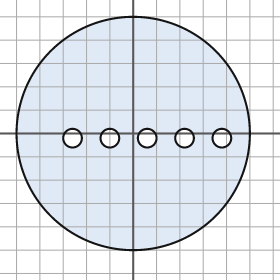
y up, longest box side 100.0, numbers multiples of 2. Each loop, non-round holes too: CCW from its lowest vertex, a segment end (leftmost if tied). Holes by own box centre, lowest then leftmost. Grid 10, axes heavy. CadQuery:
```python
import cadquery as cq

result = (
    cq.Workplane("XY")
    .moveTo(0.0, 0.0)
    .circle(50.0)
    .moveTo(-26.0, -2.0)
    .circle(4.0)
    .moveTo(-10.0, -2.0)
    .circle(4.0)
    .moveTo(6.0, -2.0)
    .circle(4.0)
    .moveTo(22.0, -2.0)
    .circle(4.0)
    .moveTo(38.0, -2.0)
    .circle(4.0)
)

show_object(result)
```